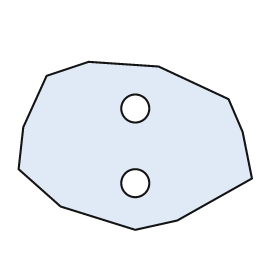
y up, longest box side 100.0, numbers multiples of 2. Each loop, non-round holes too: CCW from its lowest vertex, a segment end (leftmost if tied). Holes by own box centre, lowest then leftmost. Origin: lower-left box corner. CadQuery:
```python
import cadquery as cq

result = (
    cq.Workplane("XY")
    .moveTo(50.0, 0.0)
    .lineTo(68.0, 4.0)
    .lineTo(100.0, 22.0)
    .lineTo(96.0, 42.0)
    .lineTo(90.0, 56.0)
    .lineTo(60.0, 70.0)
    .lineTo(30.0, 72.0)
    .lineTo(12.0, 66.0)
    .lineTo(2.0, 44.0)
    .lineTo(0.0, 26.0)
    .lineTo(18.0, 10.0)
    .close()
    .moveTo(50.0, 20.0)
    .circle(6.0)
    .moveTo(50.0, 52.0)
    .circle(6.0)
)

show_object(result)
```